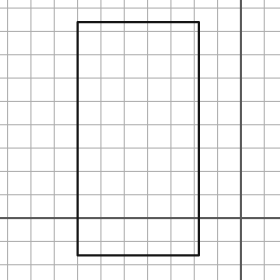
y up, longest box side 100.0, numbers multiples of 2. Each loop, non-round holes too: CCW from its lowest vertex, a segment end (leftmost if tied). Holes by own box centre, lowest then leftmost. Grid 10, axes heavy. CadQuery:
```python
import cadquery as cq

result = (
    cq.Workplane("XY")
    .moveTo(-70.0, -16.0)
    .lineTo(-18.0, -16.0)
    .lineTo(-18.0, 84.0)
    .lineTo(-70.0, 84.0)
    .close()
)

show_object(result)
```